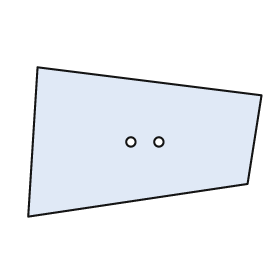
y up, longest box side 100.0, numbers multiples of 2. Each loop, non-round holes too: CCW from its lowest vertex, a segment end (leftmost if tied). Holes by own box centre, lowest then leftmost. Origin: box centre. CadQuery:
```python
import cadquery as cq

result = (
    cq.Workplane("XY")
    .moveTo(-50.0, -32.0)
    .lineTo(44.0, -18.0)
    .lineTo(50.0, 20.0)
    .lineTo(-46.0, 32.0)
    .close()
    .moveTo(-6.0, 0.0)
    .circle(2.0)
    .moveTo(6.0, 0.0)
    .circle(2.0)
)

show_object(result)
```